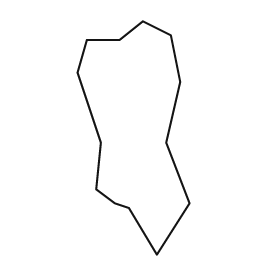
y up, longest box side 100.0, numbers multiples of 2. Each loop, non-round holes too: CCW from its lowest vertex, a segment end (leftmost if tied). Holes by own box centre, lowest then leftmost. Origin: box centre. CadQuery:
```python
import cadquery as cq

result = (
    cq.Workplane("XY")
    .moveTo(10.0, -50.0)
    .lineTo(24.0, -28.0)
    .lineTo(14.0, -2.0)
    .lineTo(20.0, 24.0)
    .lineTo(16.0, 44.0)
    .lineTo(4.0, 50.0)
    .lineTo(-6.0, 42.0)
    .lineTo(-20.0, 42.0)
    .lineTo(-24.0, 28.0)
    .lineTo(-14.0, -2.0)
    .lineTo(-16.0, -22.0)
    .lineTo(-8.0, -28.0)
    .lineTo(-2.0, -30.0)
    .close()
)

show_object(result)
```